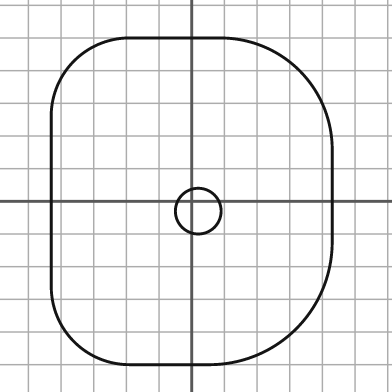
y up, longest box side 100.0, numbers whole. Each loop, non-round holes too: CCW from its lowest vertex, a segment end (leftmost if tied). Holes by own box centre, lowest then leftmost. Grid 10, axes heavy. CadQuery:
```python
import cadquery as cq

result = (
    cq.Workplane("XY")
    .moveTo(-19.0, -50.0)
    .lineTo(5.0, -50.0)
    .threePointArc((32.0, -39.0), (43.0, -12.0))
    .lineTo(43.0, 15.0)
    .threePointArc((33.0, 40.0), (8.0, 50.0))
    .lineTo(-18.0, 50.0)
    .threePointArc((-36.0, 43.0), (-43.0, 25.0))
    .lineTo(-43.0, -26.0)
    .threePointArc((-36.0, -43.0), (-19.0, -50.0))
    .close()
    .moveTo(2.0, -3.0)
    .circle(7.0)
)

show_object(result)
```